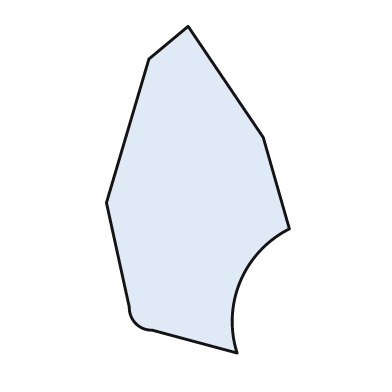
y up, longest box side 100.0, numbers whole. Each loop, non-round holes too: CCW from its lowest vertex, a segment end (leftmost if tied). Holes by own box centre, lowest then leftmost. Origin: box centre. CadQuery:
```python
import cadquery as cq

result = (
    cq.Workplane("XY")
    .moveTo(12.0, -50.0)
    .threePointArc((13.0, -28.0), (28.0, -12.0))
    .lineTo(20.0, 16.0)
    .lineTo(-3.0, 50.0)
    .lineTo(-15.0, 40.0)
    .lineTo(-28.0, -4.0)
    .lineTo(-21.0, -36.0)
    .threePointArc((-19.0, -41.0), (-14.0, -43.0))
    .close()
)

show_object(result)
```